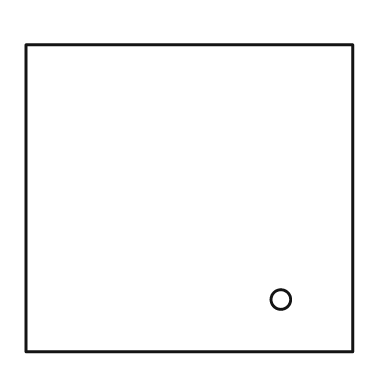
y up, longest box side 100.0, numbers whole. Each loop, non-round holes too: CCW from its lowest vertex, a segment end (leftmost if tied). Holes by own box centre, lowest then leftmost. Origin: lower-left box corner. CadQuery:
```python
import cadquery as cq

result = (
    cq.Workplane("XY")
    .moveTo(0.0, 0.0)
    .lineTo(100.0, 0.0)
    .lineTo(100.0, 94.0)
    .lineTo(0.0, 94.0)
    .close()
    .moveTo(78.0, 16.0)
    .circle(3.0)
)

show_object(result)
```